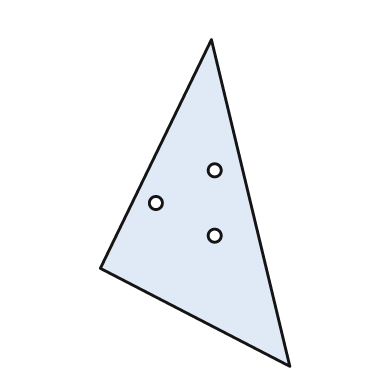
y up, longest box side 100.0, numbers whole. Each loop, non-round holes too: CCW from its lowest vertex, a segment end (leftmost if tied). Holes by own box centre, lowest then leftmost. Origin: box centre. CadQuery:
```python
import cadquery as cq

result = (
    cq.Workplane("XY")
    .moveTo(29.0, -50.0)
    .lineTo(5.0, 50.0)
    .lineTo(-29.0, -20.0)
    .close()
    .moveTo(6.0, -10.0)
    .circle(2.0)
    .moveTo(-12.0, 0.0)
    .circle(2.0)
    .moveTo(6.0, 10.0)
    .circle(2.0)
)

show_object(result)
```